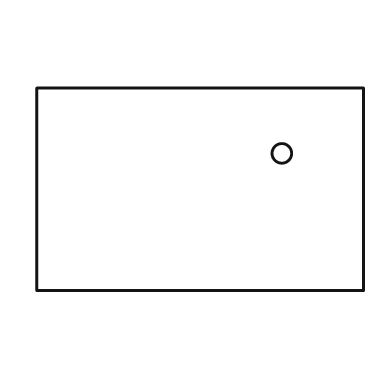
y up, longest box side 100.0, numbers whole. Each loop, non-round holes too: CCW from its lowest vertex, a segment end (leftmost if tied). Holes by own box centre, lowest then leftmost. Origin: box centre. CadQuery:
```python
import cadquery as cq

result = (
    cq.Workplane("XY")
    .moveTo(-50.0, -31.0)
    .lineTo(50.0, -31.0)
    .lineTo(50.0, 31.0)
    .lineTo(-50.0, 31.0)
    .close()
    .moveTo(25.0, 11.0)
    .circle(3.0)
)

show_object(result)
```